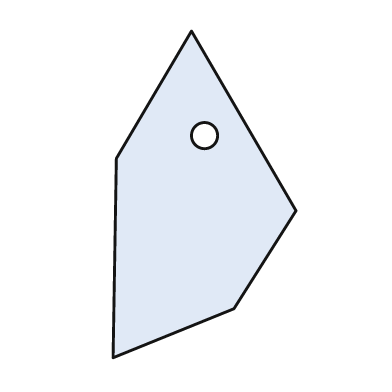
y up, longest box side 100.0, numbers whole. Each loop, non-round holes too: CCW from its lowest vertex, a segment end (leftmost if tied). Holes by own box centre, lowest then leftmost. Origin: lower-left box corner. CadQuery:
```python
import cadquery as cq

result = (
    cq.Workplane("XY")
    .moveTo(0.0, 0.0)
    .lineTo(37.0, 15.0)
    .lineTo(56.0, 45.0)
    .lineTo(24.0, 100.0)
    .lineTo(1.0, 61.0)
    .close()
    .moveTo(28.0, 68.0)
    .circle(4.0)
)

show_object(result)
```